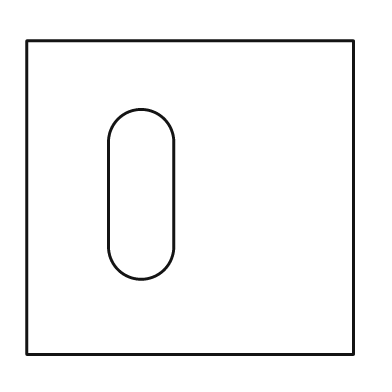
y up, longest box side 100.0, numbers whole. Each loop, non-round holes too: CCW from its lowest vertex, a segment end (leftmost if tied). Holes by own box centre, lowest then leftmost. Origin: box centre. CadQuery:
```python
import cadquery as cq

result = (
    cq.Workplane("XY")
    .moveTo(-50.0, -48.0)
    .lineTo(50.0, -48.0)
    .lineTo(50.0, 48.0)
    .lineTo(-50.0, 48.0)
    .close()
    .moveTo(-25.0, -15.0)
    .threePointArc((-15.0, -25.0), (-5.0, -15.0))
    .lineTo(-5.0, 17.0)
    .threePointArc((-15.0, 27.0), (-25.0, 17.0))
    .close()
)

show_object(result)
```